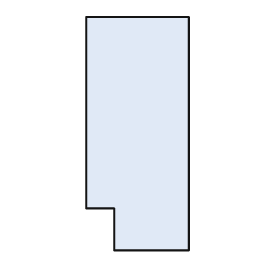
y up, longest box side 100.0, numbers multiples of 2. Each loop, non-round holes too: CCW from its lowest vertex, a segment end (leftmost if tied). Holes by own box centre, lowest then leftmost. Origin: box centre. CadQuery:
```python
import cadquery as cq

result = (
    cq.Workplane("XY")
    .moveTo(-10.0, -50.0)
    .lineTo(22.0, -50.0)
    .lineTo(22.0, 50.0)
    .lineTo(-22.0, 50.0)
    .lineTo(-22.0, -32.0)
    .lineTo(-10.0, -32.0)
    .close()
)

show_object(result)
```